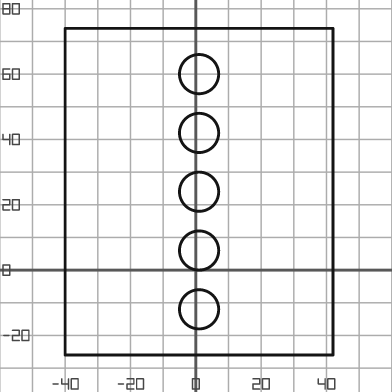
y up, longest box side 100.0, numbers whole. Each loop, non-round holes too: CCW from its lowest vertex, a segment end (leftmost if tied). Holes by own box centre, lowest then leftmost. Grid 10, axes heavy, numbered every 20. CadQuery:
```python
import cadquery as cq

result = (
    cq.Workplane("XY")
    .moveTo(-40.0, -26.0)
    .lineTo(42.0, -26.0)
    .lineTo(42.0, 74.0)
    .lineTo(-40.0, 74.0)
    .close()
    .moveTo(1.0, -12.0)
    .circle(6.0)
    .moveTo(1.0, 6.0)
    .circle(6.0)
    .moveTo(1.0, 24.0)
    .circle(6.0)
    .moveTo(1.0, 42.0)
    .circle(6.0)
    .moveTo(1.0, 60.0)
    .circle(6.0)
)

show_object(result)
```